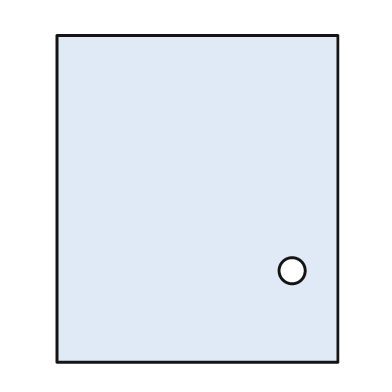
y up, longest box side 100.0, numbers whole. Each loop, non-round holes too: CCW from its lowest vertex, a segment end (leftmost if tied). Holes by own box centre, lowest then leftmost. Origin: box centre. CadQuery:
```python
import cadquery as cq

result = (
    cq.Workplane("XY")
    .moveTo(-43.0, -50.0)
    .lineTo(43.0, -50.0)
    .lineTo(43.0, 50.0)
    .lineTo(-43.0, 50.0)
    .close()
    .moveTo(29.0, -22.0)
    .circle(4.0)
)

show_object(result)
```